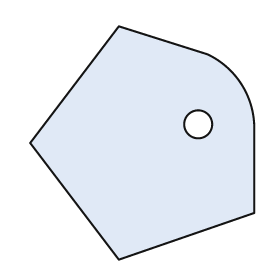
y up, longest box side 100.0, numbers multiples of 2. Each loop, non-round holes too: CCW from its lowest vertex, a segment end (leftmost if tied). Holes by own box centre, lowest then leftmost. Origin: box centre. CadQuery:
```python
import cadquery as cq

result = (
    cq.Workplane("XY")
    .moveTo(-10.0, -50.0)
    .lineTo(48.0, -30.0)
    .lineTo(48.0, 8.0)
    .threePointArc((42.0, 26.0), (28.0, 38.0))
    .lineTo(-10.0, 50.0)
    .lineTo(-48.0, 0.0)
    .close()
    .moveTo(24.0, 8.0)
    .circle(6.0)
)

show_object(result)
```